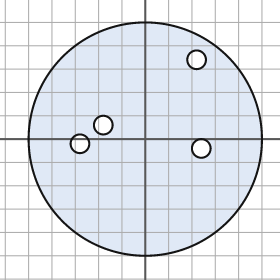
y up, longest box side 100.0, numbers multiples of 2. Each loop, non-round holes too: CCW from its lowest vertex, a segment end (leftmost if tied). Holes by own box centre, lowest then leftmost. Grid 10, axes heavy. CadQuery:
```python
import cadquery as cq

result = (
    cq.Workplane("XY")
    .moveTo(0.0, 0.0)
    .circle(50.0)
    .moveTo(24.0, -4.0)
    .circle(4.0)
    .moveTo(-28.0, -2.0)
    .circle(4.0)
    .moveTo(-18.0, 6.0)
    .circle(4.0)
    .moveTo(22.0, 34.0)
    .circle(4.0)
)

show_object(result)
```